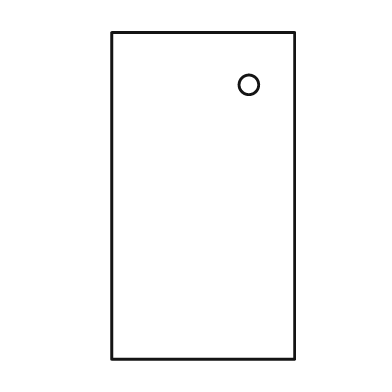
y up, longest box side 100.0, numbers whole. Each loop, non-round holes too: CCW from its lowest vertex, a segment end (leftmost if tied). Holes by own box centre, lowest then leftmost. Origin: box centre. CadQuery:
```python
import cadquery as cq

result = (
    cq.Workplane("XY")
    .moveTo(-28.0, -50.0)
    .lineTo(28.0, -50.0)
    .lineTo(28.0, 50.0)
    .lineTo(-28.0, 50.0)
    .close()
    .moveTo(14.0, 34.0)
    .circle(3.0)
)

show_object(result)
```